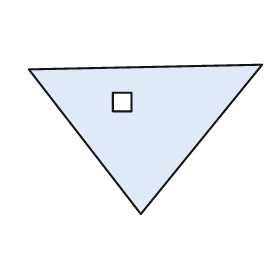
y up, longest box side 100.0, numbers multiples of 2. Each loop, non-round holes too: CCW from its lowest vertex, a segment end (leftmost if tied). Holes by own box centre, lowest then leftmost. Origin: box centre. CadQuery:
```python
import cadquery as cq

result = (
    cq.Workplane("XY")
    .moveTo(-2.0, -32.0)
    .lineTo(50.0, 32.0)
    .lineTo(-50.0, 30.0)
    .close()
    .moveTo(-14.0, 12.0)
    .lineTo(-6.0, 12.0)
    .lineTo(-6.0, 20.0)
    .lineTo(-14.0, 20.0)
    .close()
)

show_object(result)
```